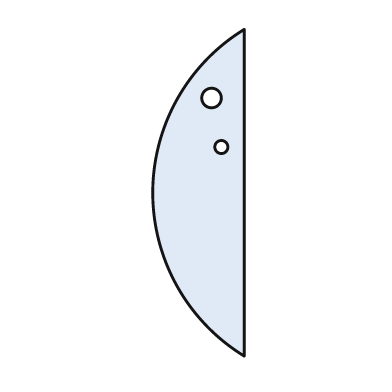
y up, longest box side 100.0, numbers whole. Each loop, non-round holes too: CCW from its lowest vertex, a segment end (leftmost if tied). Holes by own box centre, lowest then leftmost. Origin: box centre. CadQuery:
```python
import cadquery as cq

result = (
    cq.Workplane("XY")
    .moveTo(14.0, -50.0)
    .lineTo(14.0, 50.0)
    .threePointArc((-14.0, 0.0), (14.0, -50.0))
    .close()
    .moveTo(7.0, 14.0)
    .circle(2.0)
    .moveTo(4.0, 29.0)
    .circle(3.0)
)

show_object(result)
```